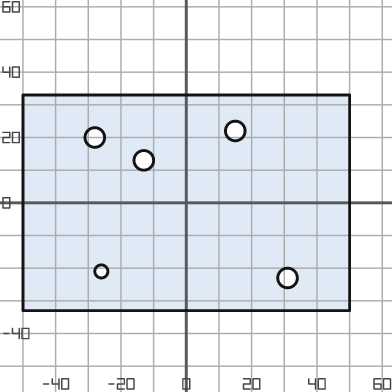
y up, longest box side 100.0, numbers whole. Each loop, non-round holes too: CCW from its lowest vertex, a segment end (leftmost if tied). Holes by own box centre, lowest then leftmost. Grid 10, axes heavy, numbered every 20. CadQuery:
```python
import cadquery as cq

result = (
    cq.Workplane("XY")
    .moveTo(-50.0, -33.0)
    .lineTo(50.0, -33.0)
    .lineTo(50.0, 33.0)
    .lineTo(-50.0, 33.0)
    .close()
    .moveTo(31.0, -23.0)
    .circle(3.0)
    .moveTo(-26.0, -21.0)
    .circle(2.0)
    .moveTo(-13.0, 13.0)
    .circle(3.0)
    .moveTo(-28.0, 20.0)
    .circle(3.0)
    .moveTo(15.0, 22.0)
    .circle(3.0)
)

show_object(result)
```